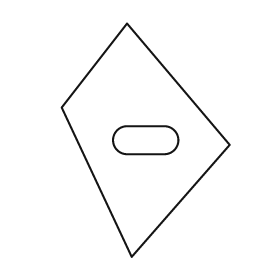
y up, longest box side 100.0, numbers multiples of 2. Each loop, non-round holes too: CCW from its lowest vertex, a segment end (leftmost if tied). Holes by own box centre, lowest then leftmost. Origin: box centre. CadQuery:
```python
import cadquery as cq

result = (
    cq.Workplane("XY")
    .moveTo(-6.0, -50.0)
    .lineTo(36.0, -2.0)
    .lineTo(-8.0, 50.0)
    .lineTo(-36.0, 14.0)
    .close()
    .moveTo(-8.0, -6.0)
    .lineTo(8.0, -6.0)
    .threePointArc((14.0, 0.0), (8.0, 6.0))
    .lineTo(-8.0, 6.0)
    .threePointArc((-14.0, 0.0), (-8.0, -6.0))
    .close()
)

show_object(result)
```